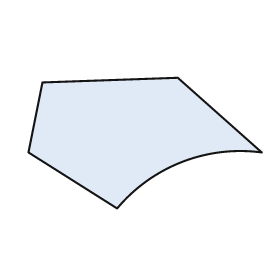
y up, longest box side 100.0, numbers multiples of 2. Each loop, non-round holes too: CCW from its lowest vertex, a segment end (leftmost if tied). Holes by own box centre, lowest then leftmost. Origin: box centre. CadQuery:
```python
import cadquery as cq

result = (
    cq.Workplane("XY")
    .moveTo(-12.0, -28.0)
    .threePointArc((16.0, -8.0), (50.0, -4.0))
    .lineTo(14.0, 28.0)
    .lineTo(-44.0, 26.0)
    .lineTo(-50.0, -4.0)
    .close()
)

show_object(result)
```